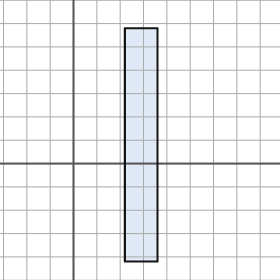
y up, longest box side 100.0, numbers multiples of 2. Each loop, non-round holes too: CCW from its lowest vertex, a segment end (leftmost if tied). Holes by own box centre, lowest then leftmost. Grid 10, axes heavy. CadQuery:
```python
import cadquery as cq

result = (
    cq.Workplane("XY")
    .moveTo(22.0, -42.0)
    .lineTo(36.0, -42.0)
    .lineTo(36.0, 58.0)
    .lineTo(22.0, 58.0)
    .close()
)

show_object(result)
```